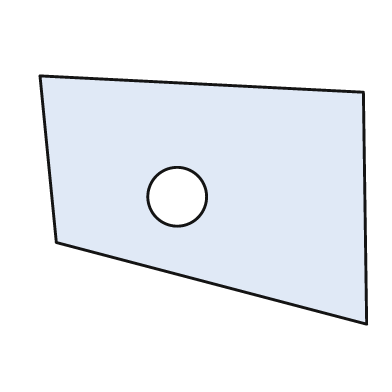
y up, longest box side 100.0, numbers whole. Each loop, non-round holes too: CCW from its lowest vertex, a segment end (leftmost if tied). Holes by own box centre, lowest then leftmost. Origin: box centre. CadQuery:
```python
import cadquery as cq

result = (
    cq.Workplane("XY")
    .moveTo(50.0, -38.0)
    .lineTo(49.0, 33.0)
    .lineTo(-50.0, 38.0)
    .lineTo(-45.0, -13.0)
    .close()
    .moveTo(-8.0, 1.0)
    .circle(9.0)
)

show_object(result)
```